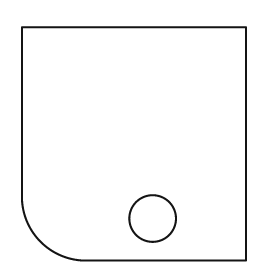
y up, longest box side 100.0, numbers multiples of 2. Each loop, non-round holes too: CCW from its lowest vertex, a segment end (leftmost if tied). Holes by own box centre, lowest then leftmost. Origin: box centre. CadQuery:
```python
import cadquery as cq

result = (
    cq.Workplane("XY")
    .moveTo(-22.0, -50.0)
    .lineTo(48.0, -50.0)
    .lineTo(48.0, 50.0)
    .lineTo(-48.0, 50.0)
    .lineTo(-48.0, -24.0)
    .threePointArc((-40.0, -42.0), (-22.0, -50.0))
    .close()
    .moveTo(8.0, -32.0)
    .circle(10.0)
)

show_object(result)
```